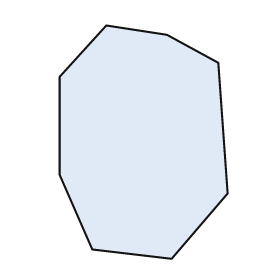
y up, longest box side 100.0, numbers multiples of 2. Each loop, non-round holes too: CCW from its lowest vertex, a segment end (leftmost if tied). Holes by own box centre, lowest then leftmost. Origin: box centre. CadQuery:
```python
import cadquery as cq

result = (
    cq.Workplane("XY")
    .moveTo(12.0, -50.0)
    .lineTo(36.0, -22.0)
    .lineTo(32.0, 34.0)
    .lineTo(10.0, 46.0)
    .lineTo(-16.0, 50.0)
    .lineTo(-36.0, 28.0)
    .lineTo(-36.0, -14.0)
    .lineTo(-22.0, -46.0)
    .close()
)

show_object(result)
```